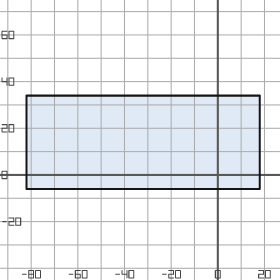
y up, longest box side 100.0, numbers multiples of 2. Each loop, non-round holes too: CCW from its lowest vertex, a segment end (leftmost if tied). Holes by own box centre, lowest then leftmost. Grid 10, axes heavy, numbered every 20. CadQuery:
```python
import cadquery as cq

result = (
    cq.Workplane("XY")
    .moveTo(-82.0, -6.0)
    .lineTo(18.0, -6.0)
    .lineTo(18.0, 34.0)
    .lineTo(-82.0, 34.0)
    .close()
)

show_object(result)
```